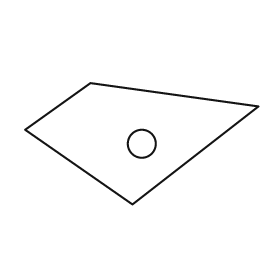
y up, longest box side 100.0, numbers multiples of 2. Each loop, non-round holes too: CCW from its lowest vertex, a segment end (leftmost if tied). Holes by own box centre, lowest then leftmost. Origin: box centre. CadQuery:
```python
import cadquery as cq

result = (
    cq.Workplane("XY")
    .moveTo(-4.0, -26.0)
    .lineTo(50.0, 16.0)
    .lineTo(-22.0, 26.0)
    .lineTo(-50.0, 6.0)
    .close()
    .moveTo(0.0, 0.0)
    .circle(6.0)
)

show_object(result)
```